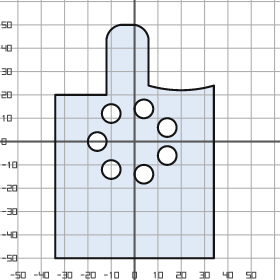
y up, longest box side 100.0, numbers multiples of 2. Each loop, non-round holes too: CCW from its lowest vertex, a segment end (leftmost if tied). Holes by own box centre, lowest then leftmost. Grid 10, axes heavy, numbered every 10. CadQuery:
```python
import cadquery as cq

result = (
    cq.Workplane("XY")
    .moveTo(-34.0, -50.0)
    .lineTo(34.0, -50.0)
    .lineTo(34.0, 24.0)
    .threePointArc((20.0, 22.0), (6.0, 24.0))
    .lineTo(6.0, 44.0)
    .threePointArc((4.0, 48.0), (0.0, 50.0))
    .lineTo(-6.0, 50.0)
    .threePointArc((-10.0, 48.0), (-12.0, 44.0))
    .lineTo(-12.0, 20.0)
    .lineTo(-34.0, 20.0)
    .close()
    .moveTo(4.0, -14.0)
    .circle(4.0)
    .moveTo(-10.0, -12.0)
    .circle(4.0)
    .moveTo(14.0, -6.0)
    .circle(4.0)
    .moveTo(-16.0, 0.0)
    .circle(4.0)
    .moveTo(14.0, 6.0)
    .circle(4.0)
    .moveTo(-10.0, 12.0)
    .circle(4.0)
    .moveTo(4.0, 14.0)
    .circle(4.0)
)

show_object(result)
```